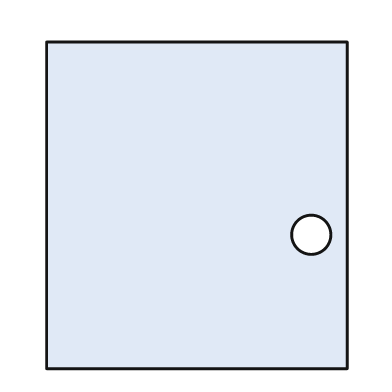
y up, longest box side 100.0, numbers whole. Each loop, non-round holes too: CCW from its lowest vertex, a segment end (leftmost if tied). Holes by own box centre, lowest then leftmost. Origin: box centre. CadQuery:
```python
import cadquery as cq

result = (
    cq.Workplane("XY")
    .moveTo(-46.0, -50.0)
    .lineTo(46.0, -50.0)
    .lineTo(46.0, 50.0)
    .lineTo(-46.0, 50.0)
    .close()
    .moveTo(35.0, -9.0)
    .circle(6.0)
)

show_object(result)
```